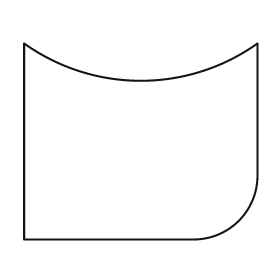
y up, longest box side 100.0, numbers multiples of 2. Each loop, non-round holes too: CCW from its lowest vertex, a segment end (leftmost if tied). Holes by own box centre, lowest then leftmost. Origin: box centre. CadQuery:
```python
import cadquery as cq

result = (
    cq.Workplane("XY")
    .moveTo(-50.0, -42.0)
    .lineTo(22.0, -42.0)
    .threePointArc((42.0, -34.0), (50.0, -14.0))
    .lineTo(50.0, 42.0)
    .threePointArc((0.0, 26.0), (-50.0, 42.0))
    .close()
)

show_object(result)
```